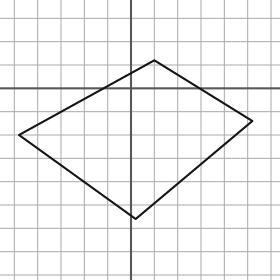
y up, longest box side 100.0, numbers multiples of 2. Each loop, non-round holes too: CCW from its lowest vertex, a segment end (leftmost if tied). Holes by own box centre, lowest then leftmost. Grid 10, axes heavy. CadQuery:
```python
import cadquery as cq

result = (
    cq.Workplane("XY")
    .moveTo(2.0, -56.0)
    .lineTo(52.0, -14.0)
    .lineTo(10.0, 12.0)
    .lineTo(-48.0, -20.0)
    .close()
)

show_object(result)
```